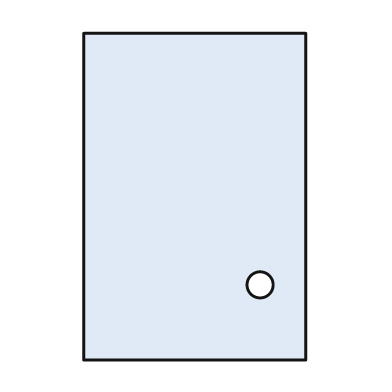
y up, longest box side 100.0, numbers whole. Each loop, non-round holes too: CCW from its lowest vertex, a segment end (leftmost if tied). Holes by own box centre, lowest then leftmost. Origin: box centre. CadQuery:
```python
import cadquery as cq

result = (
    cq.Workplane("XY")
    .moveTo(-34.0, -50.0)
    .lineTo(34.0, -50.0)
    .lineTo(34.0, 50.0)
    .lineTo(-34.0, 50.0)
    .close()
    .moveTo(20.0, -27.0)
    .circle(4.0)
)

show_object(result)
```